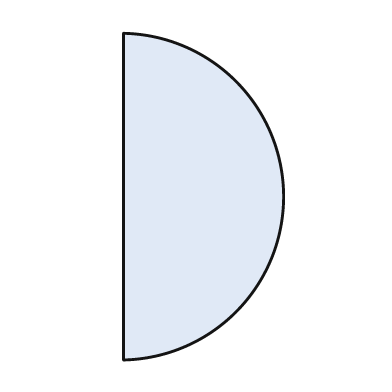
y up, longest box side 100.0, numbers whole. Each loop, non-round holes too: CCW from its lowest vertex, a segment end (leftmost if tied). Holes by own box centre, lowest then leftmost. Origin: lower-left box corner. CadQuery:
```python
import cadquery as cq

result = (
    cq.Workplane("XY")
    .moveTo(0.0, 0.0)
    .threePointArc((49.0, 50.0), (0.0, 100.0))
    .close()
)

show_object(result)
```